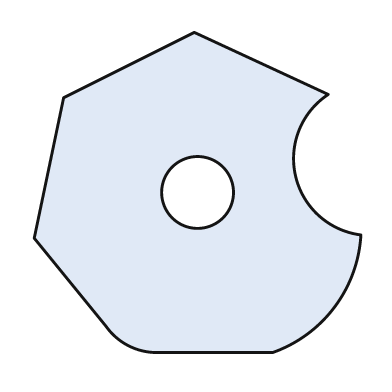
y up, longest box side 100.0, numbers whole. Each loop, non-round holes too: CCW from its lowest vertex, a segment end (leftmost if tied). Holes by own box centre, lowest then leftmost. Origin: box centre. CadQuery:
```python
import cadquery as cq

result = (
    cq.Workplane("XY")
    .moveTo(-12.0, -49.0)
    .lineTo(23.0, -49.0)
    .threePointArc((42.0, -35.0), (50.0, -13.0))
    .threePointArc((30.0, 5.0), (40.0, 30.0))
    .lineTo(-1.0, 49.0)
    .lineTo(-41.0, 29.0)
    .lineTo(-50.0, -14.0)
    .lineTo(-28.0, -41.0)
    .threePointArc((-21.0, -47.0), (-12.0, -49.0))
    .close()
    .moveTo(0.0, 0.0)
    .circle(11.0)
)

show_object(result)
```